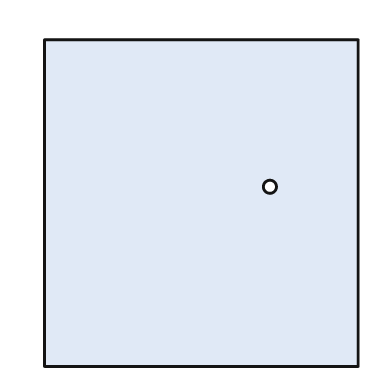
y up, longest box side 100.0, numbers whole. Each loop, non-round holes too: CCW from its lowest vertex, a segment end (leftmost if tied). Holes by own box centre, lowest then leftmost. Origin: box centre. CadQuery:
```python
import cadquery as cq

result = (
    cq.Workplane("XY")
    .moveTo(-48.0, -50.0)
    .lineTo(48.0, -50.0)
    .lineTo(48.0, 50.0)
    .lineTo(-48.0, 50.0)
    .close()
    .moveTo(21.0, 5.0)
    .circle(2.0)
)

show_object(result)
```